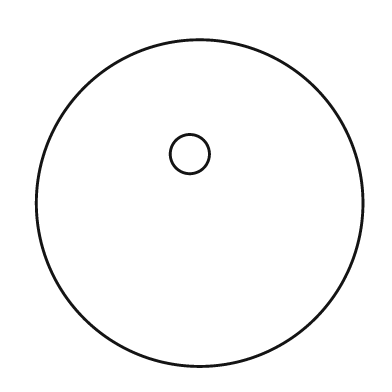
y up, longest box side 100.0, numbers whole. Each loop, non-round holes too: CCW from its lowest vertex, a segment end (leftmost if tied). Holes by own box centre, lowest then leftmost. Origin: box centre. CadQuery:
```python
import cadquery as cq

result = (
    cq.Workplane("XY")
    .moveTo(0.0, 0.0)
    .circle(50.0)
    .moveTo(-3.0, 15.0)
    .circle(6.0)
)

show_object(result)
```